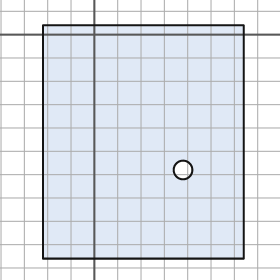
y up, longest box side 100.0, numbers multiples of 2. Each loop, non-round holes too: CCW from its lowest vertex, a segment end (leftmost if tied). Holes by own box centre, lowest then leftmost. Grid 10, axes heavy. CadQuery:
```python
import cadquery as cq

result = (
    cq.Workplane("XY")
    .moveTo(-22.0, -96.0)
    .lineTo(64.0, -96.0)
    .lineTo(64.0, 4.0)
    .lineTo(-22.0, 4.0)
    .close()
    .moveTo(38.0, -58.0)
    .circle(4.0)
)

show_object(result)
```